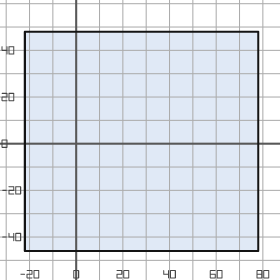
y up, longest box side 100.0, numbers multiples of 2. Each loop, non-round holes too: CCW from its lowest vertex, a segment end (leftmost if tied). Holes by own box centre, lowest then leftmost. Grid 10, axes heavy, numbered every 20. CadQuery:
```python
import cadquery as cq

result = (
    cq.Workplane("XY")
    .moveTo(-22.0, -46.0)
    .lineTo(78.0, -46.0)
    .lineTo(78.0, 48.0)
    .lineTo(-22.0, 48.0)
    .close()
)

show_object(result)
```